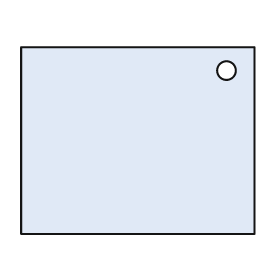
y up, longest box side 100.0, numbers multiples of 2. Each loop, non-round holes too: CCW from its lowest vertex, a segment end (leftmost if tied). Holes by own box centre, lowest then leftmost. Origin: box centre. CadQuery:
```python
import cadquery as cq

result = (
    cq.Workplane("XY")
    .moveTo(-50.0, -40.0)
    .lineTo(50.0, -40.0)
    .lineTo(50.0, 40.0)
    .lineTo(-50.0, 40.0)
    .close()
    .moveTo(38.0, 30.0)
    .circle(4.0)
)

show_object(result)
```